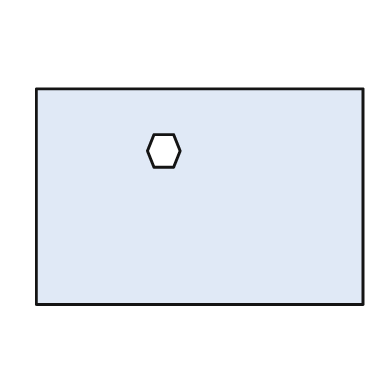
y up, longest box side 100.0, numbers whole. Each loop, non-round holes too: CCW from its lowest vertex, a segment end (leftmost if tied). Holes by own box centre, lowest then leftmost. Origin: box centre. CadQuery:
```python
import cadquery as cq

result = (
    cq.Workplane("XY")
    .moveTo(-50.0, -33.0)
    .lineTo(50.0, -33.0)
    .lineTo(50.0, 33.0)
    .lineTo(-50.0, 33.0)
    .close()
    .moveTo(-14.0, 9.0)
    .lineTo(-8.0, 9.0)
    .lineTo(-6.0, 14.0)
    .lineTo(-8.0, 19.0)
    .lineTo(-14.0, 19.0)
    .lineTo(-16.0, 14.0)
    .close()
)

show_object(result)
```